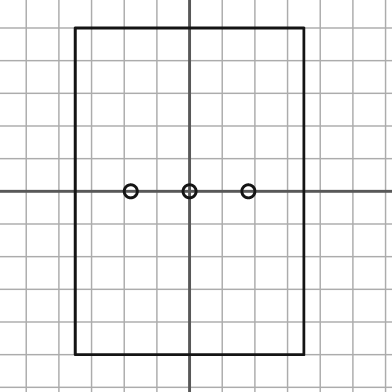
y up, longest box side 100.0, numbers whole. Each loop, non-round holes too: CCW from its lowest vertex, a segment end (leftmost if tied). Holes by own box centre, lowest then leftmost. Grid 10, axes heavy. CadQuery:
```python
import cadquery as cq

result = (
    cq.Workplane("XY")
    .moveTo(-35.0, -50.0)
    .lineTo(35.0, -50.0)
    .lineTo(35.0, 50.0)
    .lineTo(-35.0, 50.0)
    .close()
    .moveTo(-18.0, 0.0)
    .circle(2.0)
    .moveTo(0.0, 0.0)
    .circle(2.0)
    .moveTo(18.0, 0.0)
    .circle(2.0)
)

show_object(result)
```